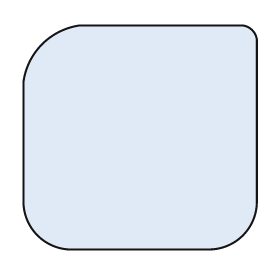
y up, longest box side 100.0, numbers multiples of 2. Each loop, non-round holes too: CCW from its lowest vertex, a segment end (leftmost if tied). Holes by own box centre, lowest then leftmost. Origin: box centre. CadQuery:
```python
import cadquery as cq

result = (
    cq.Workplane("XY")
    .moveTo(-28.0, -48.0)
    .lineTo(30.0, -48.0)
    .threePointArc((44.0, -42.0), (50.0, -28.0))
    .lineTo(50.0, 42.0)
    .threePointArc((48.0, 46.0), (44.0, 48.0))
    .lineTo(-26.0, 48.0)
    .threePointArc((-42.0, 40.0), (-50.0, 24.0))
    .lineTo(-50.0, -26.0)
    .threePointArc((-44.0, -42.0), (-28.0, -48.0))
    .close()
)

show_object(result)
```